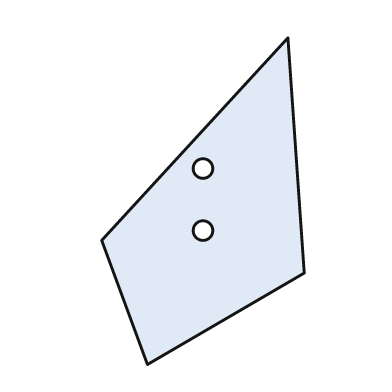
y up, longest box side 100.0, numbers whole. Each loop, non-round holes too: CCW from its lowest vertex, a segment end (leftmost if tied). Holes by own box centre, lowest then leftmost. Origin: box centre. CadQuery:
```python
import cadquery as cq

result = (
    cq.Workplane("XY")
    .moveTo(-17.0, -50.0)
    .lineTo(31.0, -22.0)
    .lineTo(26.0, 50.0)
    .lineTo(-31.0, -12.0)
    .close()
    .moveTo(0.0, -9.0)
    .circle(3.0)
    .moveTo(0.0, 10.0)
    .circle(3.0)
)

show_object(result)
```